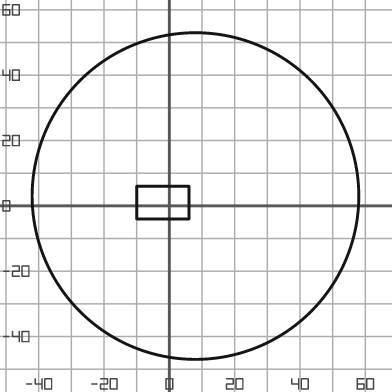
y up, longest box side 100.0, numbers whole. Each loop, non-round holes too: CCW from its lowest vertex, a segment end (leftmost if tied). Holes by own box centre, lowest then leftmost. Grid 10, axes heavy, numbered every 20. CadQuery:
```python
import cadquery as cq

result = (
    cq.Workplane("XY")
    .moveTo(8.0, 3.0)
    .circle(50.0)
    .moveTo(-10.0, -4.0)
    .lineTo(6.0, -4.0)
    .lineTo(6.0, 6.0)
    .lineTo(-10.0, 6.0)
    .close()
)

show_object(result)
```